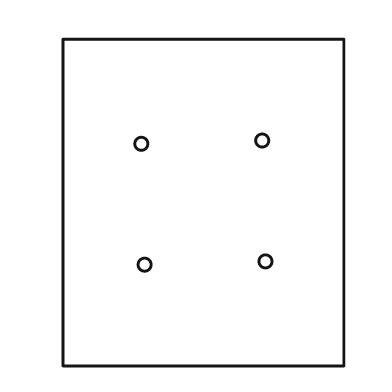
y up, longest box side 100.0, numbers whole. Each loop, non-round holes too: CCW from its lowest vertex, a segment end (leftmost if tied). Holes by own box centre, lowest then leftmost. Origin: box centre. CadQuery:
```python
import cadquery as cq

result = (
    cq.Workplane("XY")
    .moveTo(-43.0, -50.0)
    .lineTo(43.0, -50.0)
    .lineTo(43.0, 50.0)
    .lineTo(-43.0, 50.0)
    .close()
    .moveTo(-18.0, -19.0)
    .circle(2.0)
    .moveTo(19.0, -18.0)
    .circle(2.0)
    .moveTo(-19.0, 18.0)
    .circle(2.0)
    .moveTo(18.0, 19.0)
    .circle(2.0)
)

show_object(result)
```